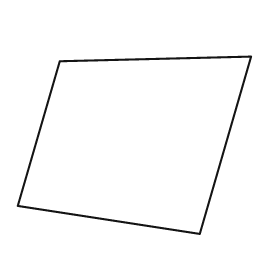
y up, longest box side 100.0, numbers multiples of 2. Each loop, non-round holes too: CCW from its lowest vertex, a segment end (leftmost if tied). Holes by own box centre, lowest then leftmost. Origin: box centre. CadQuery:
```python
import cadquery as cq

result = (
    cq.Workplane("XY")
    .moveTo(28.0, -38.0)
    .lineTo(50.0, 38.0)
    .lineTo(-32.0, 36.0)
    .lineTo(-50.0, -26.0)
    .close()
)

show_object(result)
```